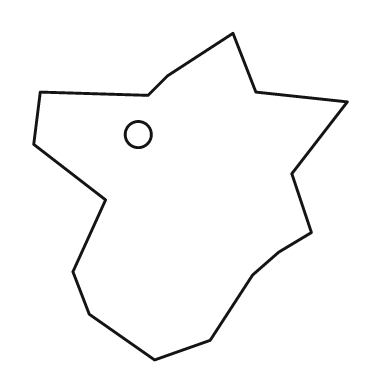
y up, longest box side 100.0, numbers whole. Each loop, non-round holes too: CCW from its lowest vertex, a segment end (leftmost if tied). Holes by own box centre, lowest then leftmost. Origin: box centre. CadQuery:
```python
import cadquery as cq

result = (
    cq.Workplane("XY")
    .moveTo(-11.0, -50.0)
    .lineTo(6.0, -44.0)
    .lineTo(19.0, -24.0)
    .lineTo(27.0, -17.0)
    .lineTo(37.0, -11.0)
    .lineTo(31.0, 7.0)
    .lineTo(48.0, 29.0)
    .lineTo(20.0, 32.0)
    .lineTo(13.0, 50.0)
    .lineTo(-7.0, 37.0)
    .lineTo(-13.0, 31.0)
    .lineTo(-46.0, 32.0)
    .lineTo(-48.0, 16.0)
    .lineTo(-26.0, -1.0)
    .lineTo(-36.0, -23.0)
    .lineTo(-31.0, -36.0)
    .close()
    .moveTo(-16.0, 19.0)
    .circle(4.0)
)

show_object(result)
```